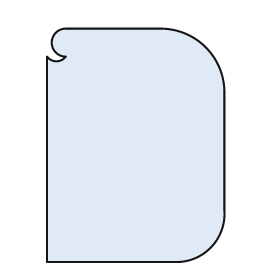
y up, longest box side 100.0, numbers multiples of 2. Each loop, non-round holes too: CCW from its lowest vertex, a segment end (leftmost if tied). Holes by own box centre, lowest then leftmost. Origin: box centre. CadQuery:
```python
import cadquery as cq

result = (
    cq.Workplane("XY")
    .moveTo(-38.0, -50.0)
    .lineTo(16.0, -50.0)
    .threePointArc((32.0, -44.0), (38.0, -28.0))
    .lineTo(38.0, 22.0)
    .threePointArc((30.0, 42.0), (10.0, 50.0))
    .lineTo(-30.0, 50.0)
    .threePointArc((-36.0, 44.0), (-30.0, 38.0))
    .threePointArc((-34.0, 36.0), (-38.0, 38.0))
    .close()
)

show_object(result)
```